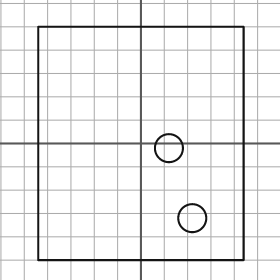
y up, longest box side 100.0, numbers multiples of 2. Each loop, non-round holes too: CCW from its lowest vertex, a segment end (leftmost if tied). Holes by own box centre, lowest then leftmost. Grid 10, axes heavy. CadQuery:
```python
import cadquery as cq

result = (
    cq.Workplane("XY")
    .moveTo(-44.0, -50.0)
    .lineTo(44.0, -50.0)
    .lineTo(44.0, 50.0)
    .lineTo(-44.0, 50.0)
    .close()
    .moveTo(22.0, -32.0)
    .circle(6.0)
    .moveTo(12.0, -2.0)
    .circle(6.0)
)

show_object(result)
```